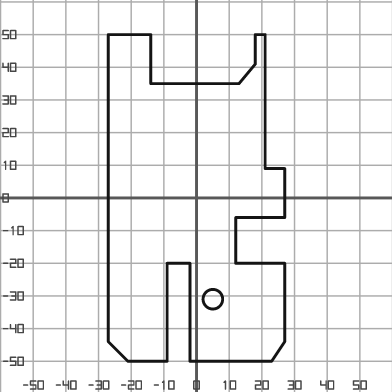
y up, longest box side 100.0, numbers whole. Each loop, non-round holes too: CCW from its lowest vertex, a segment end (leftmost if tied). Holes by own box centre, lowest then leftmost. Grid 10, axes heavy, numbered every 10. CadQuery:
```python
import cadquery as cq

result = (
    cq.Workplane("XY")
    .moveTo(-21.0, -50.0)
    .lineTo(-9.0, -50.0)
    .lineTo(-9.0, -20.0)
    .lineTo(-2.0, -20.0)
    .lineTo(-2.0, -50.0)
    .lineTo(23.0, -50.0)
    .lineTo(27.0, -44.0)
    .lineTo(27.0, -20.0)
    .lineTo(12.0, -20.0)
    .lineTo(12.0, -6.0)
    .lineTo(27.0, -6.0)
    .lineTo(27.0, 9.0)
    .lineTo(21.0, 9.0)
    .lineTo(21.0, 50.0)
    .lineTo(18.0, 50.0)
    .lineTo(18.0, 41.0)
    .lineTo(13.0, 35.0)
    .lineTo(-14.0, 35.0)
    .lineTo(-14.0, 50.0)
    .lineTo(-27.0, 50.0)
    .lineTo(-27.0, -44.0)
    .close()
    .moveTo(5.0, -31.0)
    .circle(3.0)
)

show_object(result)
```